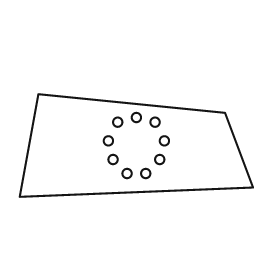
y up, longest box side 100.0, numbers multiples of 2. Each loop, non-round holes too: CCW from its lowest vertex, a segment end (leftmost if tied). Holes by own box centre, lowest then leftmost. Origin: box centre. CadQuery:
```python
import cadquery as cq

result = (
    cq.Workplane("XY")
    .moveTo(-50.0, -22.0)
    .lineTo(50.0, -18.0)
    .lineTo(38.0, 14.0)
    .lineTo(-42.0, 22.0)
    .close()
    .moveTo(-4.0, -12.0)
    .circle(2.0)
    .moveTo(4.0, -12.0)
    .circle(2.0)
    .moveTo(-10.0, -6.0)
    .circle(2.0)
    .moveTo(10.0, -6.0)
    .circle(2.0)
    .moveTo(-12.0, 2.0)
    .circle(2.0)
    .moveTo(12.0, 2.0)
    .circle(2.0)
    .moveTo(-8.0, 10.0)
    .circle(2.0)
    .moveTo(8.0, 10.0)
    .circle(2.0)
    .moveTo(0.0, 12.0)
    .circle(2.0)
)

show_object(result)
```